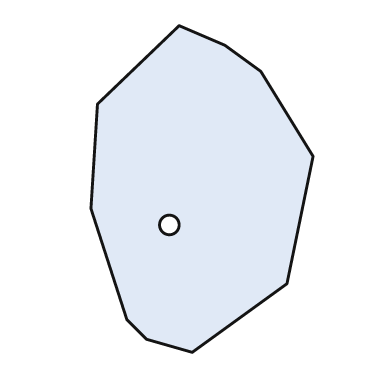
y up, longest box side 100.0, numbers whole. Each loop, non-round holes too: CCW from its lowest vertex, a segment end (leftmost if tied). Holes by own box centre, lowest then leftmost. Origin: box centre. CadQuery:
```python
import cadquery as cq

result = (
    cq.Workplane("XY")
    .moveTo(-3.0, -50.0)
    .lineTo(26.0, -29.0)
    .lineTo(34.0, 10.0)
    .lineTo(18.0, 36.0)
    .lineTo(7.0, 44.0)
    .lineTo(-7.0, 50.0)
    .lineTo(-32.0, 26.0)
    .lineTo(-34.0, -6.0)
    .lineTo(-23.0, -40.0)
    .lineTo(-17.0, -46.0)
    .close()
    .moveTo(-10.0, -11.0)
    .circle(3.0)
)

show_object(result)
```